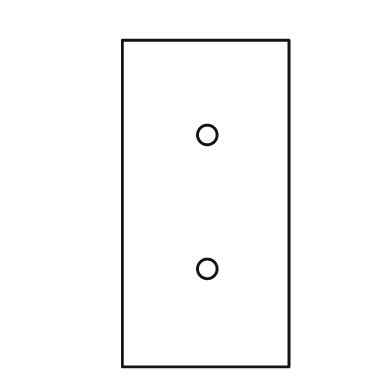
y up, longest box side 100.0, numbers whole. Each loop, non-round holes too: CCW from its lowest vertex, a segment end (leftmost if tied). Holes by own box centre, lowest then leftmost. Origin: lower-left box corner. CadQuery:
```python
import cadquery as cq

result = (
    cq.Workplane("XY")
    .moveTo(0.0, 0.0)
    .lineTo(51.0, 0.0)
    .lineTo(51.0, 100.0)
    .lineTo(0.0, 100.0)
    .close()
    .moveTo(26.0, 30.0)
    .circle(3.0)
    .moveTo(26.0, 71.0)
    .circle(3.0)
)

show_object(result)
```